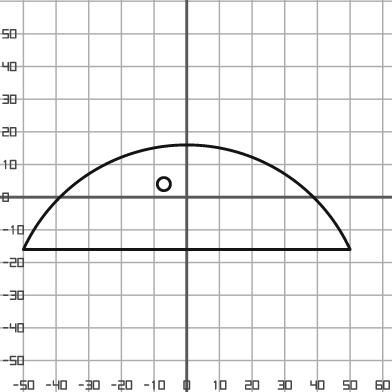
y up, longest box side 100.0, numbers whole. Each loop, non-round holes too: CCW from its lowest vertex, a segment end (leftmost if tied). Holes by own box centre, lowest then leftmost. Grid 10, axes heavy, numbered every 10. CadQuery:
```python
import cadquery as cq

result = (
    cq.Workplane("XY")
    .moveTo(-50.0, -16.0)
    .lineTo(50.0, -16.0)
    .threePointArc((0.0, 16.0), (-50.0, -16.0))
    .close()
    .moveTo(-7.0, 4.0)
    .circle(2.0)
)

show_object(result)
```